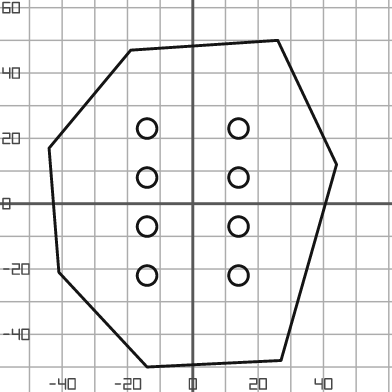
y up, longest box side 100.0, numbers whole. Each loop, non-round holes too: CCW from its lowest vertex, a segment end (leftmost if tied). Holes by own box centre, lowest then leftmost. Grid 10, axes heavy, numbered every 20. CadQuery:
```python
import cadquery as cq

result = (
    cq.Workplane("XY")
    .moveTo(-14.0, -50.0)
    .lineTo(27.0, -48.0)
    .lineTo(44.0, 12.0)
    .lineTo(26.0, 50.0)
    .lineTo(-19.0, 47.0)
    .lineTo(-44.0, 17.0)
    .lineTo(-41.0, -21.0)
    .close()
    .moveTo(-14.0, -22.0)
    .circle(3.0)
    .moveTo(14.0, -22.0)
    .circle(3.0)
    .moveTo(-14.0, -7.0)
    .circle(3.0)
    .moveTo(14.0, -7.0)
    .circle(3.0)
    .moveTo(-14.0, 8.0)
    .circle(3.0)
    .moveTo(14.0, 8.0)
    .circle(3.0)
    .moveTo(-14.0, 23.0)
    .circle(3.0)
    .moveTo(14.0, 23.0)
    .circle(3.0)
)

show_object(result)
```